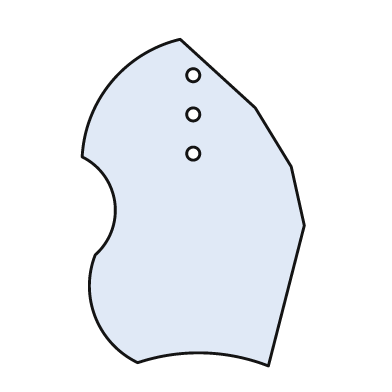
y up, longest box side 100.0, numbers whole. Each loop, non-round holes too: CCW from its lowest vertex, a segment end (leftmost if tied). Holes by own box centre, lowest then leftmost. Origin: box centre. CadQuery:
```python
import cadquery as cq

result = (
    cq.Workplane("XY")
    .moveTo(23.0, -50.0)
    .lineTo(34.0, -7.0)
    .lineTo(30.0, 11.0)
    .lineTo(19.0, 29.0)
    .lineTo(-4.0, 50.0)
    .threePointArc((-25.0, 37.0), (-34.0, 14.0))
    .threePointArc((-24.0, 0.0), (-30.0, -16.0))
    .threePointArc((-30.0, -35.0), (-17.0, -49.0))
    .threePointArc((3.0, -46.0), (23.0, -50.0))
    .close()
    .moveTo(0.0, 15.0)
    .circle(2.0)
    .moveTo(0.0, 27.0)
    .circle(2.0)
    .moveTo(0.0, 39.0)
    .circle(2.0)
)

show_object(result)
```